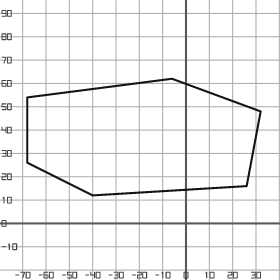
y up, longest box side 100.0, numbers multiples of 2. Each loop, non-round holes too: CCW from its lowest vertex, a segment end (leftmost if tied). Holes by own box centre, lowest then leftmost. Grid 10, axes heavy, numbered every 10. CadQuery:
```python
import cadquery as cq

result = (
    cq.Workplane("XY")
    .moveTo(-40.0, 12.0)
    .lineTo(26.0, 16.0)
    .lineTo(32.0, 48.0)
    .lineTo(-6.0, 62.0)
    .lineTo(-68.0, 54.0)
    .lineTo(-68.0, 26.0)
    .close()
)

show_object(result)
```